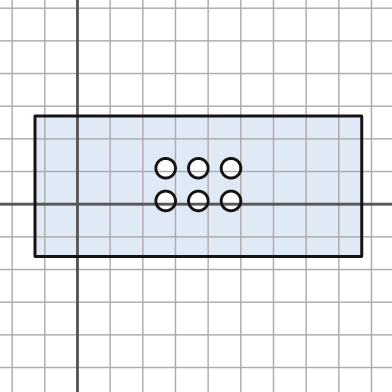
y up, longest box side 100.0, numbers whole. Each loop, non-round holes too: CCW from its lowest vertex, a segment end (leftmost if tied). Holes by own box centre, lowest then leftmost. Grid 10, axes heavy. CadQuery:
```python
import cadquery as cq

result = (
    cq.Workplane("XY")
    .moveTo(-13.0, -16.0)
    .lineTo(87.0, -16.0)
    .lineTo(87.0, 27.0)
    .lineTo(-13.0, 27.0)
    .close()
    .moveTo(27.0, 1.0)
    .circle(3.0)
    .moveTo(37.0, 1.0)
    .circle(3.0)
    .moveTo(47.0, 1.0)
    .circle(3.0)
    .moveTo(27.0, 11.0)
    .circle(3.0)
    .moveTo(37.0, 11.0)
    .circle(3.0)
    .moveTo(47.0, 11.0)
    .circle(3.0)
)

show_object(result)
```